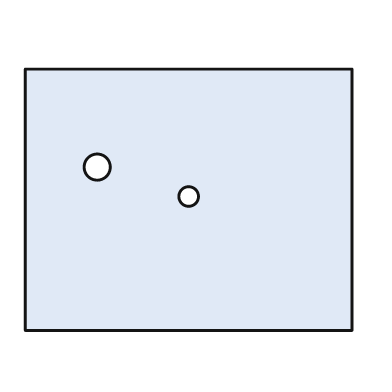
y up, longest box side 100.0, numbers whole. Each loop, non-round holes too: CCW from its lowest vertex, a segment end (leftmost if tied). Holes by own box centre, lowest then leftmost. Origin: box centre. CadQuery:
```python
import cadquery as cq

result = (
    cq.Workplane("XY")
    .moveTo(-50.0, -40.0)
    .lineTo(50.0, -40.0)
    .lineTo(50.0, 40.0)
    .lineTo(-50.0, 40.0)
    .close()
    .moveTo(0.0, 1.0)
    .circle(3.0)
    .moveTo(-28.0, 10.0)
    .circle(4.0)
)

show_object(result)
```